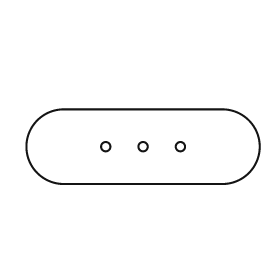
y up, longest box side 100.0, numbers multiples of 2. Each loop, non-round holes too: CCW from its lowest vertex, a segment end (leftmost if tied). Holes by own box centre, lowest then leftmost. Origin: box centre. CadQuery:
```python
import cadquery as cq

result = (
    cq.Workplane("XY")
    .moveTo(-34.0, -16.0)
    .lineTo(34.0, -16.0)
    .threePointArc((50.0, 0.0), (34.0, 16.0))
    .lineTo(-34.0, 16.0)
    .threePointArc((-50.0, 0.0), (-34.0, -16.0))
    .close()
    .moveTo(-16.0, 0.0)
    .circle(2.0)
    .moveTo(0.0, 0.0)
    .circle(2.0)
    .moveTo(16.0, 0.0)
    .circle(2.0)
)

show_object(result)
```